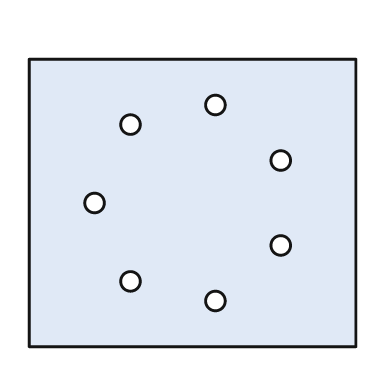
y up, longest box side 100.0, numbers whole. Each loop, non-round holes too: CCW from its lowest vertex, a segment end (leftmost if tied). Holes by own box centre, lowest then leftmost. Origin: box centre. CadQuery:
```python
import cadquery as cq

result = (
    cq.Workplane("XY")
    .moveTo(-50.0, -44.0)
    .lineTo(50.0, -44.0)
    .lineTo(50.0, 44.0)
    .lineTo(-50.0, 44.0)
    .close()
    .moveTo(7.0, -30.0)
    .circle(3.0)
    .moveTo(-19.0, -24.0)
    .circle(3.0)
    .moveTo(27.0, -13.0)
    .circle(3.0)
    .moveTo(-30.0, 0.0)
    .circle(3.0)
    .moveTo(27.0, 13.0)
    .circle(3.0)
    .moveTo(-19.0, 24.0)
    .circle(3.0)
    .moveTo(7.0, 30.0)
    .circle(3.0)
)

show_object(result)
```